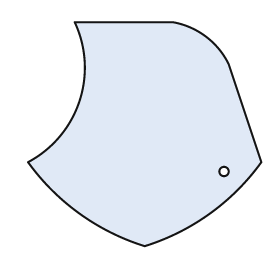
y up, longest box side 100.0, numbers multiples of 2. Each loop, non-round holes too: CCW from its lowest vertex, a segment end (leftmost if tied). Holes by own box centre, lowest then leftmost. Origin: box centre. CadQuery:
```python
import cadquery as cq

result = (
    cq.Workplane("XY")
    .moveTo(0.0, -48.0)
    .threePointArc((28.0, -34.0), (50.0, -12.0))
    .lineTo(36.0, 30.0)
    .threePointArc((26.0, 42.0), (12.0, 48.0))
    .lineTo(-30.0, 48.0)
    .threePointArc((-28.0, 14.0), (-50.0, -12.0))
    .threePointArc((-28.0, -34.0), (0.0, -48.0))
    .close()
    .moveTo(34.0, -16.0)
    .circle(2.0)
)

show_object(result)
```